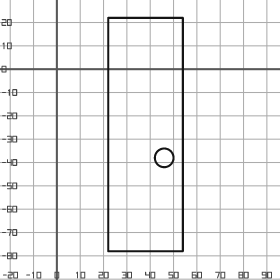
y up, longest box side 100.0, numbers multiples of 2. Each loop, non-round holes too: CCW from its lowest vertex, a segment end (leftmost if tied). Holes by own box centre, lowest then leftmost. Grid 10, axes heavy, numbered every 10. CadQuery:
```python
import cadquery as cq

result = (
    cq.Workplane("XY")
    .moveTo(22.0, -78.0)
    .lineTo(54.0, -78.0)
    .lineTo(54.0, 22.0)
    .lineTo(22.0, 22.0)
    .close()
    .moveTo(46.0, -38.0)
    .circle(4.0)
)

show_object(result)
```